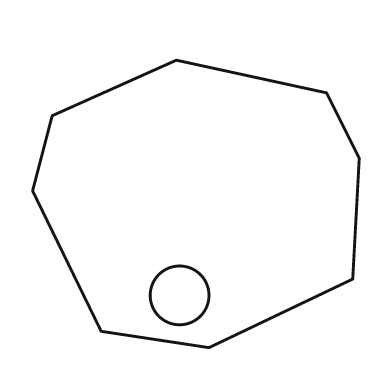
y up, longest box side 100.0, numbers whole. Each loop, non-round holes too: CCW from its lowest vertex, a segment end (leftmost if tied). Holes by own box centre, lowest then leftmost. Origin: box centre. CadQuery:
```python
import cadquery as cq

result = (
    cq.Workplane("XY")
    .moveTo(4.0, -44.0)
    .lineTo(48.0, -23.0)
    .lineTo(50.0, 14.0)
    .lineTo(40.0, 34.0)
    .lineTo(-6.0, 44.0)
    .lineTo(-44.0, 27.0)
    .lineTo(-50.0, 4.0)
    .lineTo(-29.0, -39.0)
    .close()
    .moveTo(-5.0, -28.0)
    .circle(9.0)
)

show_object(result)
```